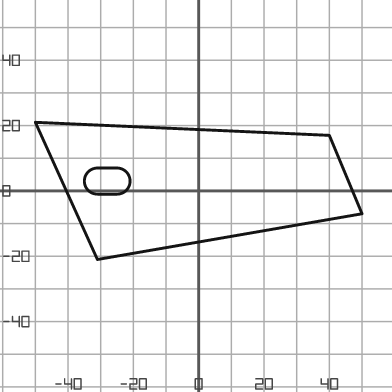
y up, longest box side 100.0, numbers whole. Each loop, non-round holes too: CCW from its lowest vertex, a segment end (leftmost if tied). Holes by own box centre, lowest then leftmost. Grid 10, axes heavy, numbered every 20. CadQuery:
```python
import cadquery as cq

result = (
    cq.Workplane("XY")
    .moveTo(-31.0, -21.0)
    .lineTo(50.0, -7.0)
    .lineTo(40.0, 17.0)
    .lineTo(-50.0, 21.0)
    .close()
    .moveTo(-31.0, -1.0)
    .lineTo(-25.0, -1.0)
    .threePointArc((-21.0, 3.0), (-25.0, 7.0))
    .lineTo(-31.0, 7.0)
    .threePointArc((-35.0, 3.0), (-31.0, -1.0))
    .close()
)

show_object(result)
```